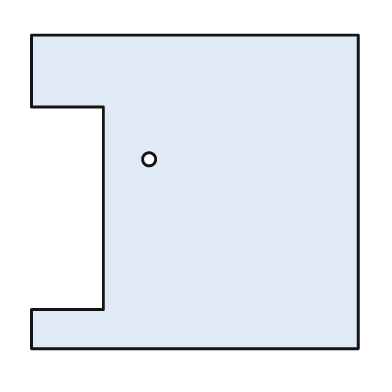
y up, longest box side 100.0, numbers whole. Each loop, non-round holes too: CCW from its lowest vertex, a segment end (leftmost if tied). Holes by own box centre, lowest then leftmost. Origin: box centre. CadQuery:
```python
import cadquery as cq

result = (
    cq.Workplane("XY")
    .moveTo(-50.0, -48.0)
    .lineTo(50.0, -48.0)
    .lineTo(50.0, 48.0)
    .lineTo(-50.0, 48.0)
    .lineTo(-50.0, 26.0)
    .lineTo(-28.0, 26.0)
    .lineTo(-28.0, -36.0)
    .lineTo(-50.0, -36.0)
    .close()
    .moveTo(-14.0, 10.0)
    .circle(2.0)
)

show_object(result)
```